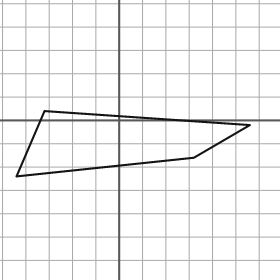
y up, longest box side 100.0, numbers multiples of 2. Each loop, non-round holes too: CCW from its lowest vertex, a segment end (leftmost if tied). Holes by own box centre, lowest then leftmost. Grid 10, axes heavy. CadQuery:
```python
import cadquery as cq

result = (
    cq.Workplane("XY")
    .moveTo(-44.0, -24.0)
    .lineTo(32.0, -16.0)
    .lineTo(56.0, -2.0)
    .lineTo(-32.0, 4.0)
    .close()
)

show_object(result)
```